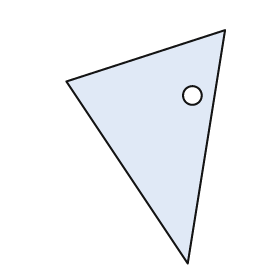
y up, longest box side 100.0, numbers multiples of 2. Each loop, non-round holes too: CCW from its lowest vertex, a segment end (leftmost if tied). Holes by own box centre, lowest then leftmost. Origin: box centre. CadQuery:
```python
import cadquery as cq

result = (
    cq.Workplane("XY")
    .moveTo(18.0, -50.0)
    .lineTo(34.0, 50.0)
    .lineTo(-34.0, 28.0)
    .close()
    .moveTo(20.0, 22.0)
    .circle(4.0)
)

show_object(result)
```